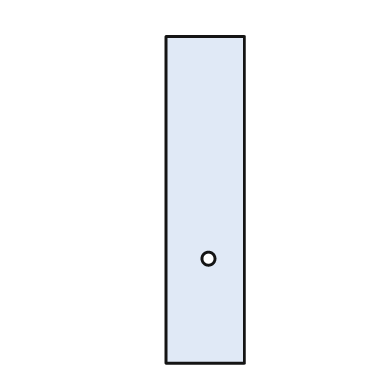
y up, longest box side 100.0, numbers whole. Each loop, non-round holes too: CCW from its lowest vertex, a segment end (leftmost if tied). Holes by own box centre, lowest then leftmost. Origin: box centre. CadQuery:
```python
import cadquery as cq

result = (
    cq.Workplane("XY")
    .moveTo(-12.0, -50.0)
    .lineTo(12.0, -50.0)
    .lineTo(12.0, 50.0)
    .lineTo(-12.0, 50.0)
    .close()
    .moveTo(1.0, -18.0)
    .circle(2.0)
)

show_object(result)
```